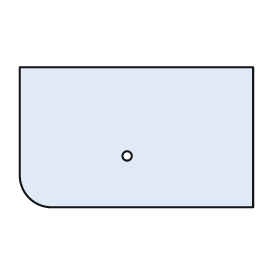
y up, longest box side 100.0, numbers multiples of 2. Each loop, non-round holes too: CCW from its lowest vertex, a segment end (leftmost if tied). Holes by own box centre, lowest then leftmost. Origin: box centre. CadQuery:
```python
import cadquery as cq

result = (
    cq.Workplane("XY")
    .moveTo(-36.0, -30.0)
    .lineTo(50.0, -30.0)
    .lineTo(50.0, 30.0)
    .lineTo(-50.0, 30.0)
    .lineTo(-50.0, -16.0)
    .threePointArc((-46.0, -26.0), (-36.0, -30.0))
    .close()
    .moveTo(-4.0, -8.0)
    .circle(2.0)
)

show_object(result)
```